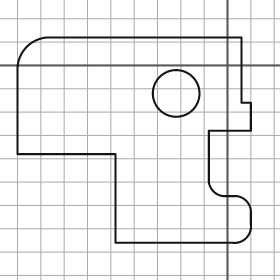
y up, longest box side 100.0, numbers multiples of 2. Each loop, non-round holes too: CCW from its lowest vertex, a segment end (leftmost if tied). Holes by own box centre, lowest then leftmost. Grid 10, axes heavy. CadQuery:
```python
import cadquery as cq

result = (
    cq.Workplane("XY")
    .moveTo(-48.0, -76.0)
    .lineTo(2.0, -76.0)
    .threePointArc((8.0, -74.0), (10.0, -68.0))
    .lineTo(10.0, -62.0)
    .threePointArc((8.0, -58.0), (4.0, -56.0))
    .lineTo(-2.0, -56.0)
    .threePointArc((-6.0, -54.0), (-8.0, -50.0))
    .lineTo(-8.0, -28.0)
    .lineTo(10.0, -28.0)
    .lineTo(10.0, -16.0)
    .lineTo(6.0, -16.0)
    .lineTo(6.0, 12.0)
    .lineTo(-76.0, 12.0)
    .threePointArc((-86.0, 8.0), (-90.0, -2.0))
    .lineTo(-90.0, -38.0)
    .lineTo(-48.0, -38.0)
    .close()
    .moveTo(-22.0, -12.0)
    .circle(10.0)
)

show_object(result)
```